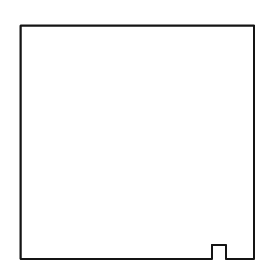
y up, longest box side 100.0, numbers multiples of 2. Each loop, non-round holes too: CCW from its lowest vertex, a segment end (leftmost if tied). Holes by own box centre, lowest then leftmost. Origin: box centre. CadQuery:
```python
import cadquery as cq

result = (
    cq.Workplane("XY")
    .moveTo(-50.0, -50.0)
    .lineTo(32.0, -50.0)
    .lineTo(32.0, -44.0)
    .lineTo(38.0, -44.0)
    .lineTo(38.0, -50.0)
    .lineTo(50.0, -50.0)
    .lineTo(50.0, 50.0)
    .lineTo(-50.0, 50.0)
    .close()
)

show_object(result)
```